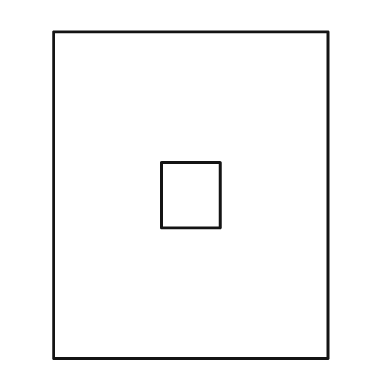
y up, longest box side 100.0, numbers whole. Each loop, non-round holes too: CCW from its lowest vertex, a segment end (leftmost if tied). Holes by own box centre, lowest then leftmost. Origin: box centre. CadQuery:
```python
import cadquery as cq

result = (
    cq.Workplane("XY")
    .moveTo(-42.0, -50.0)
    .lineTo(42.0, -50.0)
    .lineTo(42.0, 50.0)
    .lineTo(-42.0, 50.0)
    .close()
    .moveTo(-9.0, -10.0)
    .lineTo(9.0, -10.0)
    .lineTo(9.0, 10.0)
    .lineTo(-9.0, 10.0)
    .close()
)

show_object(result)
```